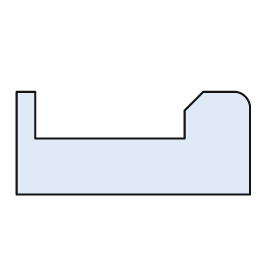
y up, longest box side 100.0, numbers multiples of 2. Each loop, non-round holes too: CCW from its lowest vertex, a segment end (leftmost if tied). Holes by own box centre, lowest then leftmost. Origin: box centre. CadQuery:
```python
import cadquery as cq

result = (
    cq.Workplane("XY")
    .moveTo(-50.0, -22.0)
    .lineTo(50.0, -22.0)
    .lineTo(50.0, 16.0)
    .threePointArc((48.0, 20.0), (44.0, 22.0))
    .lineTo(30.0, 22.0)
    .lineTo(22.0, 14.0)
    .lineTo(22.0, 2.0)
    .lineTo(-42.0, 2.0)
    .lineTo(-42.0, 22.0)
    .lineTo(-50.0, 22.0)
    .close()
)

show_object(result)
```